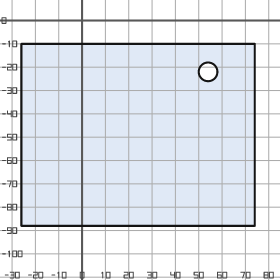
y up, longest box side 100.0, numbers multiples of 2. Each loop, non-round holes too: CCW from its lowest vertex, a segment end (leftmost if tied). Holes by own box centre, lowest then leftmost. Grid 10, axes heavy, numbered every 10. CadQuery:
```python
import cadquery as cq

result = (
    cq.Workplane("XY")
    .moveTo(-26.0, -88.0)
    .lineTo(74.0, -88.0)
    .lineTo(74.0, -10.0)
    .lineTo(-26.0, -10.0)
    .close()
    .moveTo(54.0, -22.0)
    .circle(4.0)
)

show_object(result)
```